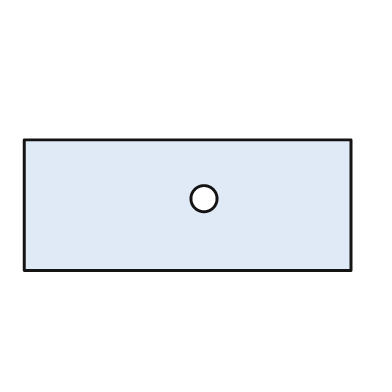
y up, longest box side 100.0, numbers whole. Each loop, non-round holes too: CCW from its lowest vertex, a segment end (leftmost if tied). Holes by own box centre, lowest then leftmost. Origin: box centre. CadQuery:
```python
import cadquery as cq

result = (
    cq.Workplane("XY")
    .moveTo(-50.0, -20.0)
    .lineTo(50.0, -20.0)
    .lineTo(50.0, 20.0)
    .lineTo(-50.0, 20.0)
    .close()
    .moveTo(5.0, 2.0)
    .circle(4.0)
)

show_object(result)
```